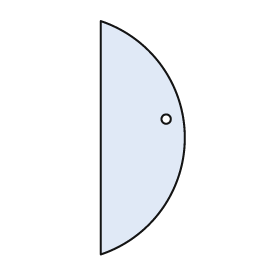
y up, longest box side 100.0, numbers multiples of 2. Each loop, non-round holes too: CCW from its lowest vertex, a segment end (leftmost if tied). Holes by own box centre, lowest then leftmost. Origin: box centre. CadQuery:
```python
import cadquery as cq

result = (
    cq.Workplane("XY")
    .moveTo(-18.0, -50.0)
    .threePointArc((18.0, 0.0), (-18.0, 50.0))
    .close()
    .moveTo(10.0, 8.0)
    .circle(2.0)
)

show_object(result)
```